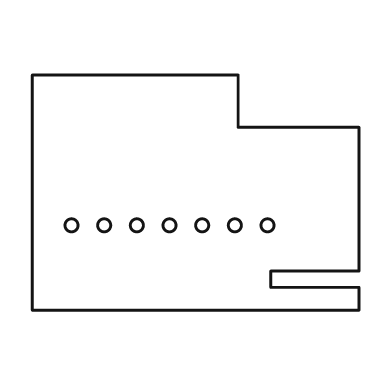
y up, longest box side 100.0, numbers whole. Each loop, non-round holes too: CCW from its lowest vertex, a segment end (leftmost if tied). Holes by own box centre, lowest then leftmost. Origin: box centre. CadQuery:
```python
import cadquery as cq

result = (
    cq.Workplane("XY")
    .moveTo(-50.0, -36.0)
    .lineTo(50.0, -36.0)
    .lineTo(50.0, -29.0)
    .lineTo(23.0, -29.0)
    .lineTo(23.0, -24.0)
    .lineTo(50.0, -24.0)
    .lineTo(50.0, 20.0)
    .lineTo(13.0, 20.0)
    .lineTo(13.0, 36.0)
    .lineTo(-50.0, 36.0)
    .close()
    .moveTo(-38.0, -10.0)
    .circle(2.0)
    .moveTo(-28.0, -10.0)
    .circle(2.0)
    .moveTo(-18.0, -10.0)
    .circle(2.0)
    .moveTo(-8.0, -10.0)
    .circle(2.0)
    .moveTo(2.0, -10.0)
    .circle(2.0)
    .moveTo(12.0, -10.0)
    .circle(2.0)
    .moveTo(22.0, -10.0)
    .circle(2.0)
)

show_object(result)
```